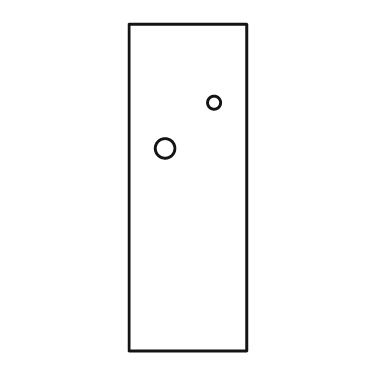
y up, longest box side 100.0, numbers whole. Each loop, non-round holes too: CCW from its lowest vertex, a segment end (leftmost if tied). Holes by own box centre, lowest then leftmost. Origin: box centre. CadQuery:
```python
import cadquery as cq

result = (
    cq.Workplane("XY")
    .moveTo(-18.0, -50.0)
    .lineTo(18.0, -50.0)
    .lineTo(18.0, 50.0)
    .lineTo(-18.0, 50.0)
    .close()
    .moveTo(-7.0, 12.0)
    .circle(3.0)
    .moveTo(8.0, 26.0)
    .circle(2.0)
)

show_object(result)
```